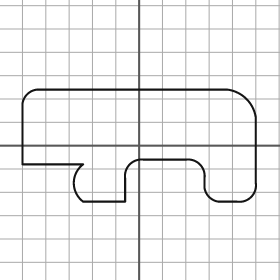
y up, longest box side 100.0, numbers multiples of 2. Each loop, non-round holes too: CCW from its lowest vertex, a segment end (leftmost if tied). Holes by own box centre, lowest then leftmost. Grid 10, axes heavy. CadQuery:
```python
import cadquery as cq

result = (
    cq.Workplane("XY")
    .moveTo(-24.0, -24.0)
    .lineTo(-6.0, -24.0)
    .lineTo(-6.0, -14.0)
    .threePointArc((-4.0, -8.0), (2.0, -6.0))
    .lineTo(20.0, -6.0)
    .threePointArc((26.0, -8.0), (28.0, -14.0))
    .lineTo(28.0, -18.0)
    .threePointArc((30.0, -22.0), (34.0, -24.0))
    .lineTo(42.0, -24.0)
    .threePointArc((48.0, -22.0), (50.0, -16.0))
    .lineTo(50.0, 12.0)
    .threePointArc((46.0, 20.0), (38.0, 24.0))
    .lineTo(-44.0, 24.0)
    .threePointArc((-48.0, 22.0), (-50.0, 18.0))
    .lineTo(-50.0, -8.0)
    .lineTo(-24.0, -8.0)
    .threePointArc((-28.0, -16.0), (-24.0, -24.0))
    .close()
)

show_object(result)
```